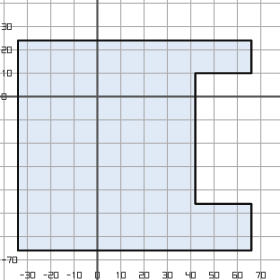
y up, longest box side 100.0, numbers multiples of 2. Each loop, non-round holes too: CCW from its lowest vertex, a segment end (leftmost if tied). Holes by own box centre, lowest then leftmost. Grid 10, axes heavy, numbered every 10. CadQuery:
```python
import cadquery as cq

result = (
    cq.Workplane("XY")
    .moveTo(-34.0, -66.0)
    .lineTo(66.0, -66.0)
    .lineTo(66.0, -46.0)
    .lineTo(42.0, -46.0)
    .lineTo(42.0, 10.0)
    .lineTo(66.0, 10.0)
    .lineTo(66.0, 24.0)
    .lineTo(-34.0, 24.0)
    .close()
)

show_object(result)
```